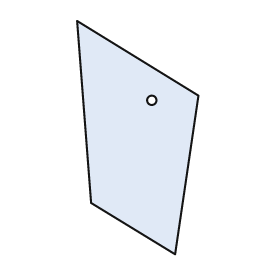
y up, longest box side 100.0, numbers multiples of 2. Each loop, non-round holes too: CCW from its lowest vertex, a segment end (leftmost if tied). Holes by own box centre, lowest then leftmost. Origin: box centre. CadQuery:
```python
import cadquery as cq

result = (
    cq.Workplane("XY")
    .moveTo(16.0, -50.0)
    .lineTo(26.0, 18.0)
    .lineTo(-26.0, 50.0)
    .lineTo(-20.0, -28.0)
    .close()
    .moveTo(6.0, 16.0)
    .circle(2.0)
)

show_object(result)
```